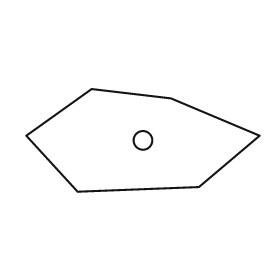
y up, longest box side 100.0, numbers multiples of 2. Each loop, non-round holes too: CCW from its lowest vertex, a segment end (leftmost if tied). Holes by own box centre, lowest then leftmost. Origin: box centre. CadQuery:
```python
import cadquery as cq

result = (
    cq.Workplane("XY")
    .moveTo(-28.0, -22.0)
    .lineTo(24.0, -20.0)
    .lineTo(50.0, 2.0)
    .lineTo(12.0, 18.0)
    .lineTo(-22.0, 22.0)
    .lineTo(-50.0, 2.0)
    .close()
    .moveTo(0.0, 0.0)
    .circle(4.0)
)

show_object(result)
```